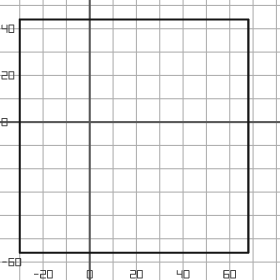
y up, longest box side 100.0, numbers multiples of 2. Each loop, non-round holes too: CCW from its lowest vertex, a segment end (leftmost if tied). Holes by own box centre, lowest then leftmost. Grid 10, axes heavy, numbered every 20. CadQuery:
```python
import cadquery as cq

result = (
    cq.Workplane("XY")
    .moveTo(-30.0, -56.0)
    .lineTo(68.0, -56.0)
    .lineTo(68.0, 44.0)
    .lineTo(-30.0, 44.0)
    .close()
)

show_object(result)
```